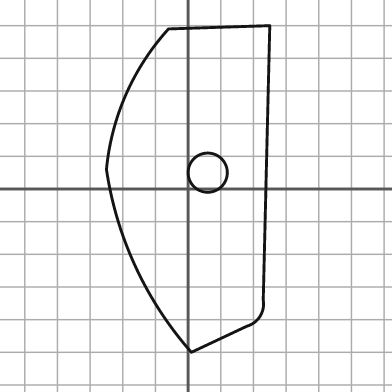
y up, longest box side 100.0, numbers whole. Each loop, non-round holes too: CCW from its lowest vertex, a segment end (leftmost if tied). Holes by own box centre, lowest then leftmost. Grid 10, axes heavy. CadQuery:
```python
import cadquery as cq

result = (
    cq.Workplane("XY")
    .moveTo(1.0, -50.0)
    .lineTo(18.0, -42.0)
    .threePointArc((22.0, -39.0), (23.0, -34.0))
    .lineTo(25.0, 50.0)
    .lineTo(-6.0, 49.0)
    .threePointArc((-19.0, 29.0), (-25.0, 6.0))
    .threePointArc((-16.0, -24.0), (1.0, -50.0))
    .close()
    .moveTo(6.0, 5.0)
    .circle(6.0)
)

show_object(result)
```